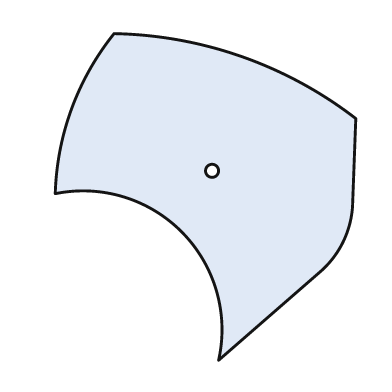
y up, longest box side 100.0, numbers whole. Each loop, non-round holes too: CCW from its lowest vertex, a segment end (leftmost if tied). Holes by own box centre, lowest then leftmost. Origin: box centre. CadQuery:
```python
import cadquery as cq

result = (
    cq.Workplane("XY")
    .moveTo(4.0, -50.0)
    .lineTo(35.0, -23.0)
    .threePointArc((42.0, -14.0), (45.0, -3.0))
    .lineTo(46.0, 24.0)
    .threePointArc((11.0, 43.0), (-28.0, 50.0))
    .threePointArc((-41.0, 27.0), (-46.0, 1.0))
    .threePointArc((-7.0, -11.0), (4.0, -50.0))
    .close()
    .moveTo(2.0, 8.0)
    .circle(2.0)
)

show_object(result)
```